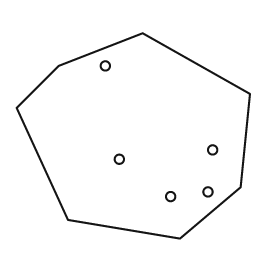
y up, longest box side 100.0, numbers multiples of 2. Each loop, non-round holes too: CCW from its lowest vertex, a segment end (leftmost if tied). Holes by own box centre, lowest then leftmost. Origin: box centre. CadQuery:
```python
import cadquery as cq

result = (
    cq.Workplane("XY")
    .moveTo(20.0, -44.0)
    .lineTo(46.0, -22.0)
    .lineTo(50.0, 18.0)
    .lineTo(4.0, 44.0)
    .lineTo(-32.0, 30.0)
    .lineTo(-50.0, 12.0)
    .lineTo(-28.0, -36.0)
    .close()
    .moveTo(16.0, -26.0)
    .circle(2.0)
    .moveTo(32.0, -24.0)
    .circle(2.0)
    .moveTo(-6.0, -10.0)
    .circle(2.0)
    .moveTo(34.0, -6.0)
    .circle(2.0)
    .moveTo(-12.0, 30.0)
    .circle(2.0)
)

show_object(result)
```